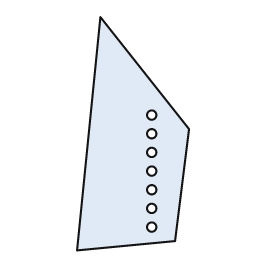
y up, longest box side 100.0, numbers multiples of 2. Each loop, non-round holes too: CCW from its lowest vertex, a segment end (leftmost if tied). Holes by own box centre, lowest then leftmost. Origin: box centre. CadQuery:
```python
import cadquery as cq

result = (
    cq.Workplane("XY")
    .moveTo(-24.0, -50.0)
    .lineTo(18.0, -46.0)
    .lineTo(24.0, 2.0)
    .lineTo(-14.0, 50.0)
    .close()
    .moveTo(8.0, -40.0)
    .circle(2.0)
    .moveTo(8.0, -32.0)
    .circle(2.0)
    .moveTo(8.0, -24.0)
    .circle(2.0)
    .moveTo(8.0, -16.0)
    .circle(2.0)
    .moveTo(8.0, -8.0)
    .circle(2.0)
    .moveTo(8.0, 0.0)
    .circle(2.0)
    .moveTo(8.0, 8.0)
    .circle(2.0)
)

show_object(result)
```